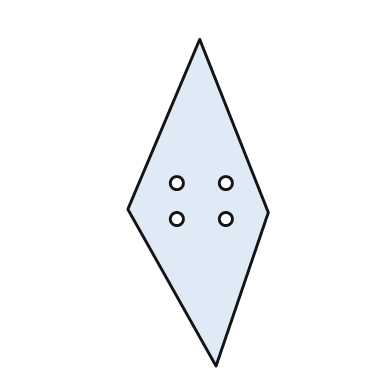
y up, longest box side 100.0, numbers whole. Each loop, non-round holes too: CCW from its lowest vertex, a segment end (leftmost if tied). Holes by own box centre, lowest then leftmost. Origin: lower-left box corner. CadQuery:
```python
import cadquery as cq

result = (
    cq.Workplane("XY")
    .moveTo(27.0, 0.0)
    .lineTo(43.0, 47.0)
    .lineTo(22.0, 100.0)
    .lineTo(0.0, 48.0)
    .close()
    .moveTo(15.0, 45.0)
    .circle(2.0)
    .moveTo(30.0, 45.0)
    .circle(2.0)
    .moveTo(15.0, 56.0)
    .circle(2.0)
    .moveTo(30.0, 56.0)
    .circle(2.0)
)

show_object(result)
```